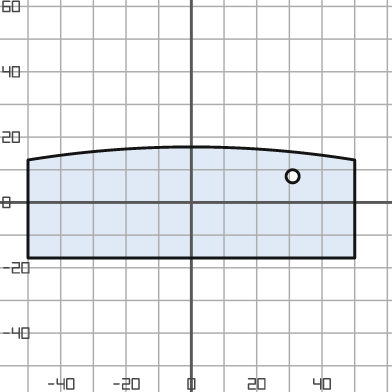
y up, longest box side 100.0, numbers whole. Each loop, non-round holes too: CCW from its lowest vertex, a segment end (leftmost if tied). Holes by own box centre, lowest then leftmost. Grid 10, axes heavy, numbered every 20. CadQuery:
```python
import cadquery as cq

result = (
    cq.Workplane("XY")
    .moveTo(-50.0, -17.0)
    .lineTo(50.0, -17.0)
    .lineTo(50.0, 13.0)
    .threePointArc((0.0, 17.0), (-50.0, 13.0))
    .close()
    .moveTo(31.0, 8.0)
    .circle(2.0)
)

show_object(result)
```